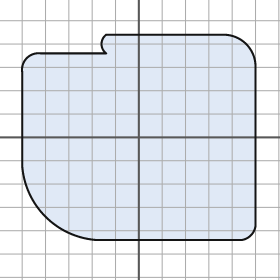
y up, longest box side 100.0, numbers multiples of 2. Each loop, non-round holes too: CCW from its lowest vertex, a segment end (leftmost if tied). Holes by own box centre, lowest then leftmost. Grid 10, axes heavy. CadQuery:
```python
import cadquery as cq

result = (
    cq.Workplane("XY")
    .moveTo(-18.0, -44.0)
    .lineTo(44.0, -44.0)
    .threePointArc((48.0, -42.0), (50.0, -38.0))
    .lineTo(50.0, 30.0)
    .threePointArc((46.0, 40.0), (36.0, 44.0))
    .lineTo(-14.0, 44.0)
    .threePointArc((-16.0, 40.0), (-14.0, 36.0))
    .lineTo(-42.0, 36.0)
    .threePointArc((-48.0, 34.0), (-50.0, 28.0))
    .lineTo(-50.0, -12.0)
    .threePointArc((-40.0, -34.0), (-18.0, -44.0))
    .close()
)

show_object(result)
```